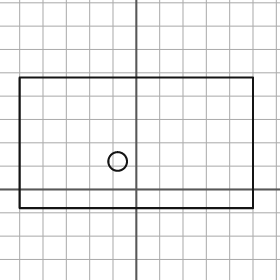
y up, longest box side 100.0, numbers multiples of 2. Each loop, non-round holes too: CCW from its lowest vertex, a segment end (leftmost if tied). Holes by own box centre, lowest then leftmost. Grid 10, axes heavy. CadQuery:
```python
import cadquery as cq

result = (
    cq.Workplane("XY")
    .moveTo(-50.0, -8.0)
    .lineTo(50.0, -8.0)
    .lineTo(50.0, 48.0)
    .lineTo(-50.0, 48.0)
    .close()
    .moveTo(-8.0, 12.0)
    .circle(4.0)
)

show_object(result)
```